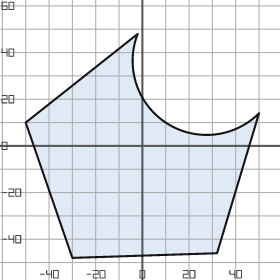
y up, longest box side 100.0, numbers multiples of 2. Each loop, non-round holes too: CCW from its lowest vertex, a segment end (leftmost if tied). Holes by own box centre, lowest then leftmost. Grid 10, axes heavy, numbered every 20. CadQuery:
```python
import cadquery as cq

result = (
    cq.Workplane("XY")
    .moveTo(-30.0, -48.0)
    .lineTo(32.0, -46.0)
    .lineTo(50.0, 14.0)
    .threePointArc((10.0, 10.0), (-2.0, 48.0))
    .lineTo(-50.0, 10.0)
    .close()
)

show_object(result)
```